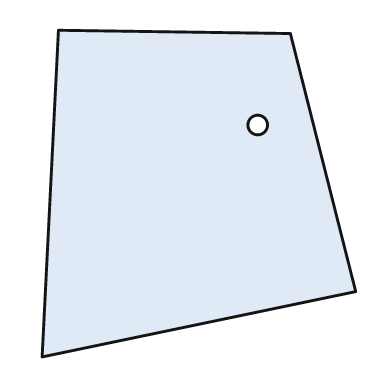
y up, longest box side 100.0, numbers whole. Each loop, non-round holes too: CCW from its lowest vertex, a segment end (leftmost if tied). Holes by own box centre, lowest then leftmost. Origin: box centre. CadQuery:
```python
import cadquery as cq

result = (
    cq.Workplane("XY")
    .moveTo(-48.0, -50.0)
    .lineTo(48.0, -30.0)
    .lineTo(28.0, 49.0)
    .lineTo(-43.0, 50.0)
    .close()
    .moveTo(18.0, 21.0)
    .circle(3.0)
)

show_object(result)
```